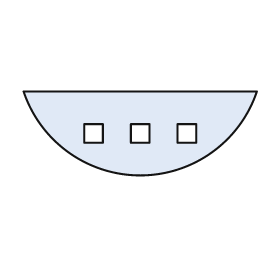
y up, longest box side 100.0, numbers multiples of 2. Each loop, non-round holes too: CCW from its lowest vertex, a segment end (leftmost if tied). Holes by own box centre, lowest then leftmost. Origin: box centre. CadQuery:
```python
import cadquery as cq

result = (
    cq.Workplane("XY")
    .moveTo(-50.0, 18.0)
    .threePointArc((0.0, -18.0), (50.0, 18.0))
    .close()
    .moveTo(-24.0, -4.0)
    .lineTo(-16.0, -4.0)
    .lineTo(-16.0, 4.0)
    .lineTo(-24.0, 4.0)
    .close()
    .moveTo(-4.0, -4.0)
    .lineTo(4.0, -4.0)
    .lineTo(4.0, 4.0)
    .lineTo(-4.0, 4.0)
    .close()
    .moveTo(16.0, -4.0)
    .lineTo(24.0, -4.0)
    .lineTo(24.0, 4.0)
    .lineTo(16.0, 4.0)
    .close()
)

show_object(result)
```